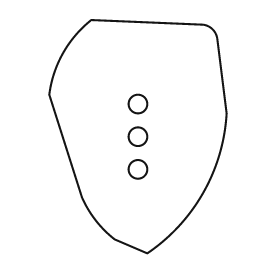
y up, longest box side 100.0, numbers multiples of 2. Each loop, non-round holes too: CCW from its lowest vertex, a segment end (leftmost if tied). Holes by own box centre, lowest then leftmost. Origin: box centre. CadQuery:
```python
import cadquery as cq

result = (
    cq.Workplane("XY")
    .moveTo(4.0, -50.0)
    .threePointArc((28.0, -24.0), (38.0, 10.0))
    .lineTo(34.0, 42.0)
    .threePointArc((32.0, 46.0), (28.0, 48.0))
    .lineTo(-20.0, 50.0)
    .threePointArc((-32.0, 36.0), (-38.0, 18.0))
    .lineTo(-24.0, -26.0)
    .threePointArc((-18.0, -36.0), (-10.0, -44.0))
    .close()
    .moveTo(0.0, -14.0)
    .circle(4.0)
    .moveTo(0.0, 0.0)
    .circle(4.0)
    .moveTo(0.0, 14.0)
    .circle(4.0)
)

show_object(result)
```